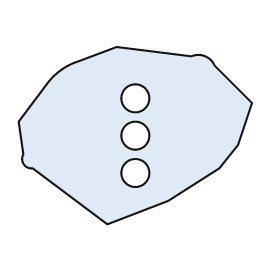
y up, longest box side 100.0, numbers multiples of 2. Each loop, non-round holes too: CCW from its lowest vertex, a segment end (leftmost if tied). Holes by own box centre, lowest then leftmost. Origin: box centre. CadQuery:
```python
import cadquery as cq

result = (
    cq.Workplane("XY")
    .moveTo(-12.0, -38.0)
    .lineTo(14.0, -28.0)
    .lineTo(36.0, -14.0)
    .lineTo(44.0, -4.0)
    .lineTo(50.0, 14.0)
    .lineTo(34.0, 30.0)
    .threePointArc((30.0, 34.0), (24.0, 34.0))
    .lineTo(-8.0, 38.0)
    .lineTo(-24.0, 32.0)
    .threePointArc((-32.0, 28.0), (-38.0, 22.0))
    .lineTo(-50.0, 6.0)
    .lineTo(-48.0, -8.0)
    .threePointArc((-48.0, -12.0), (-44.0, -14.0))
    .close()
    .moveTo(0.0, -16.0)
    .circle(6.0)
    .moveTo(0.0, 0.0)
    .circle(6.0)
    .moveTo(0.0, 16.0)
    .circle(6.0)
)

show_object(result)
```